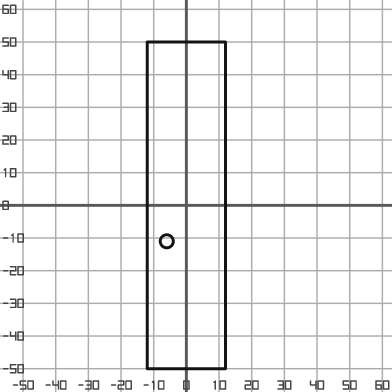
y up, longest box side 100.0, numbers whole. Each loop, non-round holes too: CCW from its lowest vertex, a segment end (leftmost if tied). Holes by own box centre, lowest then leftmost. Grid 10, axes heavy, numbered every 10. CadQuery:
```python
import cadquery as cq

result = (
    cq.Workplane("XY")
    .moveTo(-12.0, -50.0)
    .lineTo(12.0, -50.0)
    .lineTo(12.0, 50.0)
    .lineTo(-12.0, 50.0)
    .close()
    .moveTo(-6.0, -11.0)
    .circle(2.0)
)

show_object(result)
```